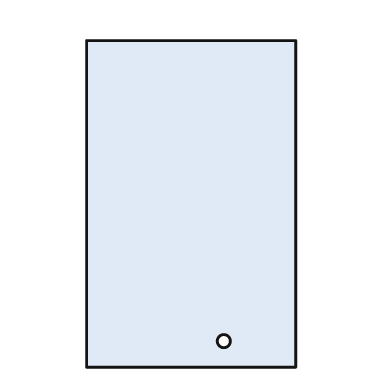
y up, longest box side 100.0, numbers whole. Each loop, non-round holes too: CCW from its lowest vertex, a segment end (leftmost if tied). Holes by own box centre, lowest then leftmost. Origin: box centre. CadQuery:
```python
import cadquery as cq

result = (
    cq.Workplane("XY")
    .moveTo(-32.0, -50.0)
    .lineTo(32.0, -50.0)
    .lineTo(32.0, 50.0)
    .lineTo(-32.0, 50.0)
    .close()
    .moveTo(10.0, -42.0)
    .circle(2.0)
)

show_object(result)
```